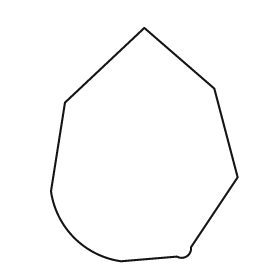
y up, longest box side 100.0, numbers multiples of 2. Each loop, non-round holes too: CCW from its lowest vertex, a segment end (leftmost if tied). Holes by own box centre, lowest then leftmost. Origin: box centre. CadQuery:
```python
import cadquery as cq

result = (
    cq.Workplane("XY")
    .moveTo(-10.0, -50.0)
    .lineTo(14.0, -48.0)
    .threePointArc((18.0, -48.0), (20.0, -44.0))
    .lineTo(40.0, -14.0)
    .lineTo(30.0, 24.0)
    .lineTo(0.0, 50.0)
    .lineTo(-34.0, 18.0)
    .lineTo(-40.0, -20.0)
    .threePointArc((-30.0, -40.0), (-10.0, -50.0))
    .close()
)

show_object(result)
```